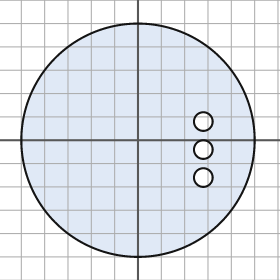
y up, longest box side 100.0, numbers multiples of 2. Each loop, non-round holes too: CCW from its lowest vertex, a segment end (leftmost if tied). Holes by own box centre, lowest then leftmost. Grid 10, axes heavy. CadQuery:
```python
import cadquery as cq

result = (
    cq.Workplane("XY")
    .moveTo(0.0, 0.0)
    .circle(50.0)
    .moveTo(28.0, -16.0)
    .circle(4.0)
    .moveTo(28.0, -4.0)
    .circle(4.0)
    .moveTo(28.0, 8.0)
    .circle(4.0)
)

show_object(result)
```